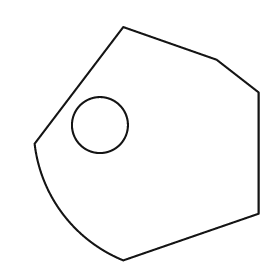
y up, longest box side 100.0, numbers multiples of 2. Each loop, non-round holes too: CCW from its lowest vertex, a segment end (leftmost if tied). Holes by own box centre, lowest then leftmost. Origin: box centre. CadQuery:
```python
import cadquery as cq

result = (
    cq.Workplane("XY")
    .moveTo(-10.0, -50.0)
    .lineTo(48.0, -30.0)
    .lineTo(48.0, 22.0)
    .lineTo(30.0, 36.0)
    .lineTo(-10.0, 50.0)
    .lineTo(-48.0, 0.0)
    .threePointArc((-36.0, -30.0), (-10.0, -50.0))
    .close()
    .moveTo(-20.0, 8.0)
    .circle(12.0)
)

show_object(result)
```